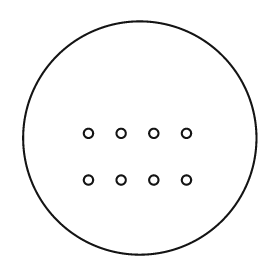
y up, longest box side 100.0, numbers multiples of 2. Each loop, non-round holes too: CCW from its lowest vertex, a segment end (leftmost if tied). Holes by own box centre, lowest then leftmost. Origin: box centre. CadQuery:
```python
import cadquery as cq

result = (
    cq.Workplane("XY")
    .moveTo(0.0, 0.0)
    .circle(50.0)
    .moveTo(-22.0, -18.0)
    .circle(2.0)
    .moveTo(-8.0, -18.0)
    .circle(2.0)
    .moveTo(6.0, -18.0)
    .circle(2.0)
    .moveTo(20.0, -18.0)
    .circle(2.0)
    .moveTo(-22.0, 2.0)
    .circle(2.0)
    .moveTo(-8.0, 2.0)
    .circle(2.0)
    .moveTo(6.0, 2.0)
    .circle(2.0)
    .moveTo(20.0, 2.0)
    .circle(2.0)
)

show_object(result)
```